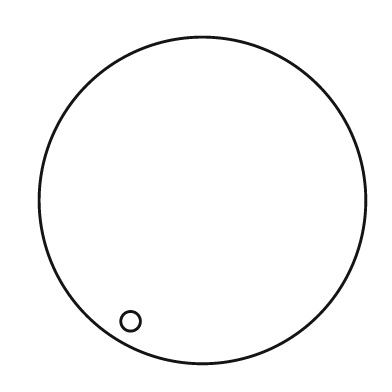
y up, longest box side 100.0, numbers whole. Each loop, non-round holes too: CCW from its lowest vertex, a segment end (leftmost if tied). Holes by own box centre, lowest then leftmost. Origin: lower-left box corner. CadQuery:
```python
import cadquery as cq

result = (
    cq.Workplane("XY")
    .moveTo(50.0, 50.0)
    .circle(50.0)
    .moveTo(28.0, 13.0)
    .circle(3.0)
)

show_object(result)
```